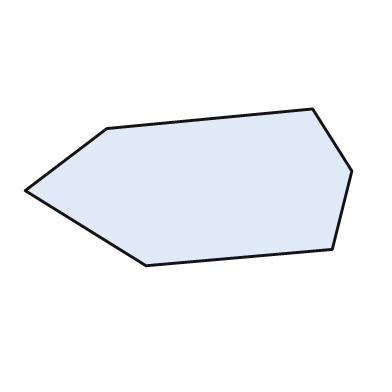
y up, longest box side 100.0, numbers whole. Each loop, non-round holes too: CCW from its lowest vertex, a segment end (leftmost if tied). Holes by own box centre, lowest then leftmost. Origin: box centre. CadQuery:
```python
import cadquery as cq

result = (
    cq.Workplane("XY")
    .moveTo(-13.0, -24.0)
    .lineTo(44.0, -19.0)
    .lineTo(50.0, 5.0)
    .lineTo(38.0, 24.0)
    .lineTo(-25.0, 18.0)
    .lineTo(-50.0, -1.0)
    .close()
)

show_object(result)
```